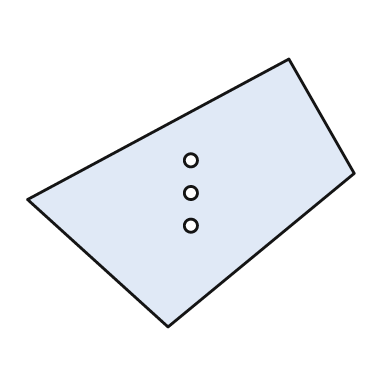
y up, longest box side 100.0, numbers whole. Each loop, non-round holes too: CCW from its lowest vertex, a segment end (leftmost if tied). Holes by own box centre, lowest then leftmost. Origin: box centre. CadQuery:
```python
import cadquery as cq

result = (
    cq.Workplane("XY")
    .moveTo(-7.0, -41.0)
    .lineTo(50.0, 6.0)
    .lineTo(30.0, 41.0)
    .lineTo(-50.0, -2.0)
    .close()
    .moveTo(0.0, -10.0)
    .circle(2.0)
    .moveTo(0.0, 0.0)
    .circle(2.0)
    .moveTo(0.0, 10.0)
    .circle(2.0)
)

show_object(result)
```